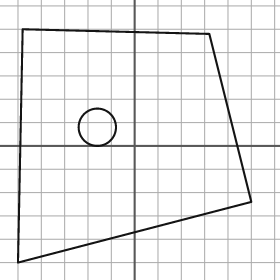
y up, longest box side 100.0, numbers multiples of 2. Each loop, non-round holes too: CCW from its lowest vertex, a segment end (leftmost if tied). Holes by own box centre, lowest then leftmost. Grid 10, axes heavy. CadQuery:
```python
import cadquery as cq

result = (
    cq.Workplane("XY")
    .moveTo(-50.0, -50.0)
    .lineTo(50.0, -24.0)
    .lineTo(32.0, 48.0)
    .lineTo(-48.0, 50.0)
    .close()
    .moveTo(-16.0, 8.0)
    .circle(8.0)
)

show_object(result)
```